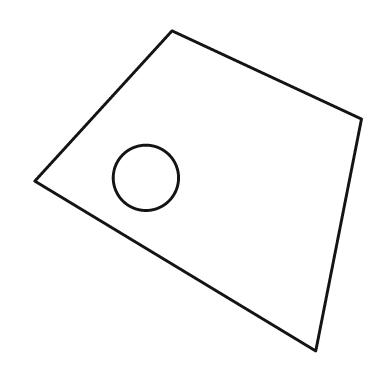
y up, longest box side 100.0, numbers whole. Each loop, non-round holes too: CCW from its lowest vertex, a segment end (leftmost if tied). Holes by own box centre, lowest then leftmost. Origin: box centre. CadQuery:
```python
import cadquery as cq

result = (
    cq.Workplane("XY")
    .moveTo(36.0, -49.0)
    .lineTo(50.0, 22.0)
    .lineTo(-8.0, 49.0)
    .lineTo(-50.0, 3.0)
    .close()
    .moveTo(-16.0, 4.0)
    .circle(10.0)
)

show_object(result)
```